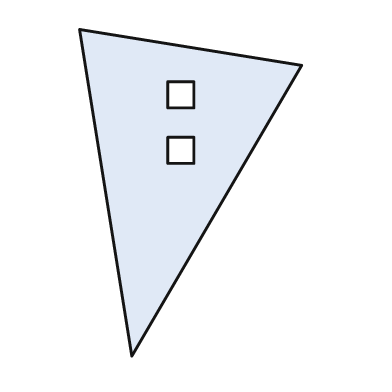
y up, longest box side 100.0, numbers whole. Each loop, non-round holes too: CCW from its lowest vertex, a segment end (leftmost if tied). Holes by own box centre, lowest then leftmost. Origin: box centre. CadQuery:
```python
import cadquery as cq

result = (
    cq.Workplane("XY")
    .moveTo(-18.0, -50.0)
    .lineTo(34.0, 39.0)
    .lineTo(-34.0, 50.0)
    .close()
    .moveTo(-7.0, 9.0)
    .lineTo(1.0, 9.0)
    .lineTo(1.0, 17.0)
    .lineTo(-7.0, 17.0)
    .close()
    .moveTo(-7.0, 26.0)
    .lineTo(1.0, 26.0)
    .lineTo(1.0, 34.0)
    .lineTo(-7.0, 34.0)
    .close()
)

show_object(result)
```